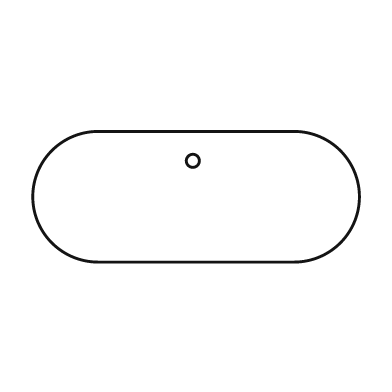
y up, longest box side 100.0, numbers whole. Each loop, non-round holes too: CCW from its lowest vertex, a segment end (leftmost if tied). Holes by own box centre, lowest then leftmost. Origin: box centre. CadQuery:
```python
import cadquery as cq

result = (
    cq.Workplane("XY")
    .moveTo(-30.0, -20.0)
    .lineTo(30.0, -20.0)
    .threePointArc((50.0, 0.0), (30.0, 20.0))
    .lineTo(-30.0, 20.0)
    .threePointArc((-50.0, 0.0), (-30.0, -20.0))
    .close()
    .moveTo(-1.0, 11.0)
    .circle(2.0)
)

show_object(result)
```